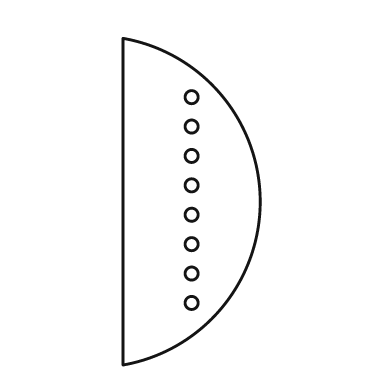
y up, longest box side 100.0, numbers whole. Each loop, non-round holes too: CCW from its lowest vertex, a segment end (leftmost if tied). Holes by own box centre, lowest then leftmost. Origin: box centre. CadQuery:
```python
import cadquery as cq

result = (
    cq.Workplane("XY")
    .moveTo(-21.0, -50.0)
    .threePointArc((21.0, 0.0), (-21.0, 50.0))
    .close()
    .moveTo(0.0, -31.0)
    .circle(2.0)
    .moveTo(0.0, -22.0)
    .circle(2.0)
    .moveTo(0.0, -13.0)
    .circle(2.0)
    .moveTo(0.0, -4.0)
    .circle(2.0)
    .moveTo(0.0, 5.0)
    .circle(2.0)
    .moveTo(0.0, 14.0)
    .circle(2.0)
    .moveTo(0.0, 23.0)
    .circle(2.0)
    .moveTo(0.0, 32.0)
    .circle(2.0)
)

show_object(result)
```